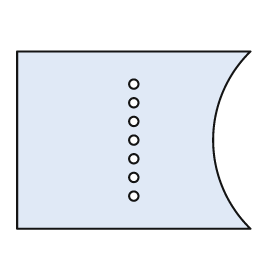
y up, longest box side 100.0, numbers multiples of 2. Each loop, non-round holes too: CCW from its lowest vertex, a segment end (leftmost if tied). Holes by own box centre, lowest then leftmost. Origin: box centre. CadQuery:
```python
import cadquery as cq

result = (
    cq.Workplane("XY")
    .moveTo(-50.0, -38.0)
    .lineTo(50.0, -38.0)
    .threePointArc((34.0, 0.0), (50.0, 38.0))
    .lineTo(-50.0, 38.0)
    .close()
    .moveTo(0.0, -24.0)
    .circle(2.0)
    .moveTo(0.0, -16.0)
    .circle(2.0)
    .moveTo(0.0, -8.0)
    .circle(2.0)
    .moveTo(0.0, 0.0)
    .circle(2.0)
    .moveTo(0.0, 8.0)
    .circle(2.0)
    .moveTo(0.0, 16.0)
    .circle(2.0)
    .moveTo(0.0, 24.0)
    .circle(2.0)
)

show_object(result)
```